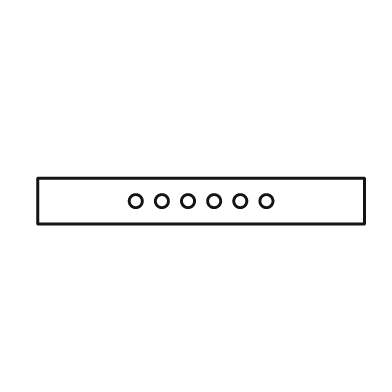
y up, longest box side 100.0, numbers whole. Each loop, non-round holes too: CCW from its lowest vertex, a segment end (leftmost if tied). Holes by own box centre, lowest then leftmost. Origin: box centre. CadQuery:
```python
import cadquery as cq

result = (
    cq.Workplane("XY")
    .moveTo(-50.0, -7.0)
    .lineTo(50.0, -7.0)
    .lineTo(50.0, 7.0)
    .lineTo(-50.0, 7.0)
    .close()
    .moveTo(-20.0, 0.0)
    .circle(2.0)
    .moveTo(-12.0, 0.0)
    .circle(2.0)
    .moveTo(-4.0, 0.0)
    .circle(2.0)
    .moveTo(4.0, 0.0)
    .circle(2.0)
    .moveTo(12.0, 0.0)
    .circle(2.0)
    .moveTo(20.0, 0.0)
    .circle(2.0)
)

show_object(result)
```